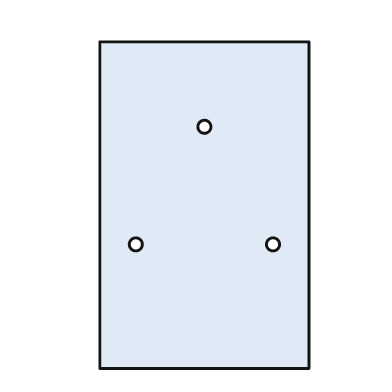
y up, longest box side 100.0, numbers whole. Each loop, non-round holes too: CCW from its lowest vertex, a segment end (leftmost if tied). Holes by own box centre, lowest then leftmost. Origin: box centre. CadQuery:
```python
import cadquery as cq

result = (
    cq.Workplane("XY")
    .moveTo(-32.0, -50.0)
    .lineTo(32.0, -50.0)
    .lineTo(32.0, 50.0)
    .lineTo(-32.0, 50.0)
    .close()
    .moveTo(-21.0, -12.0)
    .circle(2.0)
    .moveTo(21.0, -12.0)
    .circle(2.0)
    .moveTo(0.0, 24.0)
    .circle(2.0)
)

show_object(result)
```